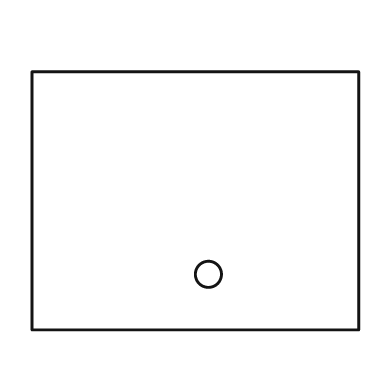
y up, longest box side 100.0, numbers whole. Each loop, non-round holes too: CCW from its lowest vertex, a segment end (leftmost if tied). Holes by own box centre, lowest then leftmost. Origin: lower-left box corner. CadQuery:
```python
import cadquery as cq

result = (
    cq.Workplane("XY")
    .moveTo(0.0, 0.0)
    .lineTo(100.0, 0.0)
    .lineTo(100.0, 79.0)
    .lineTo(0.0, 79.0)
    .close()
    .moveTo(54.0, 17.0)
    .circle(4.0)
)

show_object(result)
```